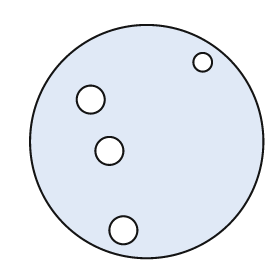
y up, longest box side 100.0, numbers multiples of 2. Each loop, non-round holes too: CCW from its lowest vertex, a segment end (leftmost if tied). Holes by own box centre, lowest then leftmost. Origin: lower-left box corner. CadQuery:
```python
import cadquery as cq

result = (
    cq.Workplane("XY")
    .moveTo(50.0, 50.0)
    .circle(50.0)
    .moveTo(40.0, 12.0)
    .circle(6.0)
    .moveTo(34.0, 46.0)
    .circle(6.0)
    .moveTo(26.0, 68.0)
    .circle(6.0)
    .moveTo(74.0, 84.0)
    .circle(4.0)
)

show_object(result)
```